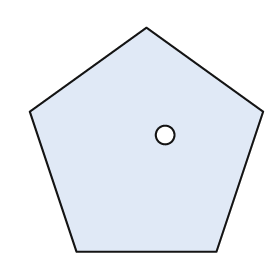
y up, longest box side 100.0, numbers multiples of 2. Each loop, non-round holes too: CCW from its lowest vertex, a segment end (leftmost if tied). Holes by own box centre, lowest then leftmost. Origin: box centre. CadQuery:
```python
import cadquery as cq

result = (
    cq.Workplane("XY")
    .moveTo(-30.0, -48.0)
    .lineTo(30.0, -48.0)
    .lineTo(50.0, 12.0)
    .lineTo(0.0, 48.0)
    .lineTo(-50.0, 12.0)
    .close()
    .moveTo(8.0, 2.0)
    .circle(4.0)
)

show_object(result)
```